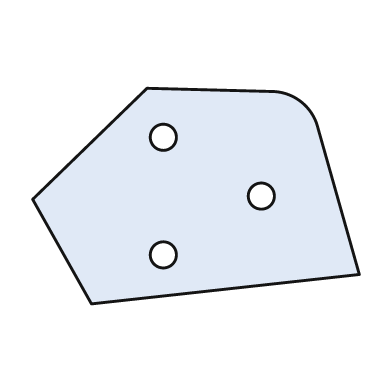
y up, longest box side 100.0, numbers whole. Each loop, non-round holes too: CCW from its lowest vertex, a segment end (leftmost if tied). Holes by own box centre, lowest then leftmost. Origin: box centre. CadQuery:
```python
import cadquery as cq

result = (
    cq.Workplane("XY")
    .moveTo(-32.0, -33.0)
    .lineTo(50.0, -24.0)
    .lineTo(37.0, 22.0)
    .threePointArc((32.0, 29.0), (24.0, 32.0))
    .lineTo(-15.0, 33.0)
    .lineTo(-50.0, -1.0)
    .close()
    .moveTo(-10.0, -18.0)
    .circle(4.0)
    .moveTo(20.0, 0.0)
    .circle(4.0)
    .moveTo(-10.0, 18.0)
    .circle(4.0)
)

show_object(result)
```